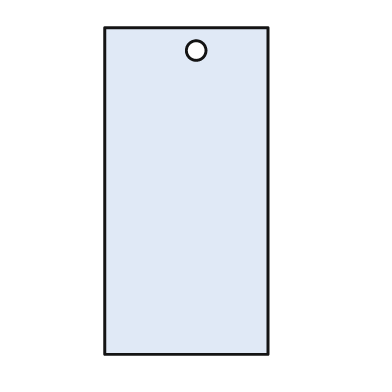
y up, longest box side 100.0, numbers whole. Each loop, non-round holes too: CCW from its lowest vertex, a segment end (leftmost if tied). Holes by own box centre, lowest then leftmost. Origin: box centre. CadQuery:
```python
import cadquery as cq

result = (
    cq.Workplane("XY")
    .moveTo(-25.0, -50.0)
    .lineTo(25.0, -50.0)
    .lineTo(25.0, 50.0)
    .lineTo(-25.0, 50.0)
    .close()
    .moveTo(3.0, 43.0)
    .circle(3.0)
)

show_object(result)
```